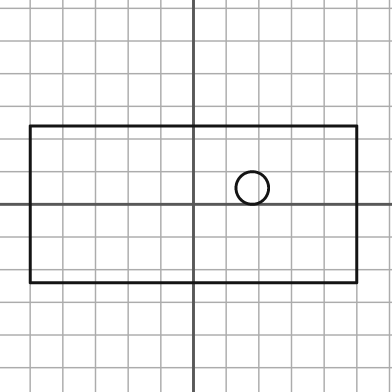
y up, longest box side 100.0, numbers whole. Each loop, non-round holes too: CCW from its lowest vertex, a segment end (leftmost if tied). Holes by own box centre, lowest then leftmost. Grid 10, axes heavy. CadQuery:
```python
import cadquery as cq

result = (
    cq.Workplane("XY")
    .moveTo(-50.0, -24.0)
    .lineTo(50.0, -24.0)
    .lineTo(50.0, 24.0)
    .lineTo(-50.0, 24.0)
    .close()
    .moveTo(18.0, 5.0)
    .circle(5.0)
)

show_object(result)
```